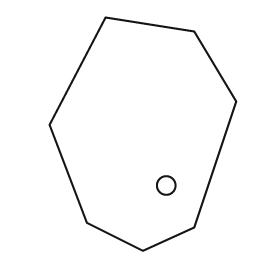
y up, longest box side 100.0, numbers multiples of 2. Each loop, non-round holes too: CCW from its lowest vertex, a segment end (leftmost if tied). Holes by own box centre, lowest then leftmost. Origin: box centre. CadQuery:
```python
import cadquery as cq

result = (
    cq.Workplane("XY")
    .moveTo(0.0, -50.0)
    .lineTo(22.0, -40.0)
    .lineTo(40.0, 14.0)
    .lineTo(22.0, 44.0)
    .lineTo(-16.0, 50.0)
    .lineTo(-40.0, 4.0)
    .lineTo(-24.0, -38.0)
    .close()
    .moveTo(10.0, -22.0)
    .circle(4.0)
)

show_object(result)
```